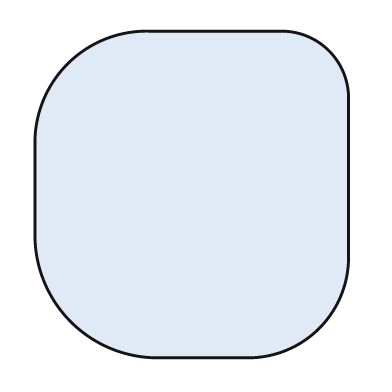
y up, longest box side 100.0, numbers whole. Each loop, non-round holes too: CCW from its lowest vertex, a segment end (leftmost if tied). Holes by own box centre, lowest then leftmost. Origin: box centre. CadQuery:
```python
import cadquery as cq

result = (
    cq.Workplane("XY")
    .moveTo(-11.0, -50.0)
    .lineTo(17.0, -50.0)
    .threePointArc((39.0, -41.0), (48.0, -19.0))
    .lineTo(48.0, 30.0)
    .threePointArc((42.0, 44.0), (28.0, 50.0))
    .lineTo(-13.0, 50.0)
    .threePointArc((-38.0, 40.0), (-48.0, 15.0))
    .lineTo(-48.0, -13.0)
    .threePointArc((-37.0, -39.0), (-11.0, -50.0))
    .close()
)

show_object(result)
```